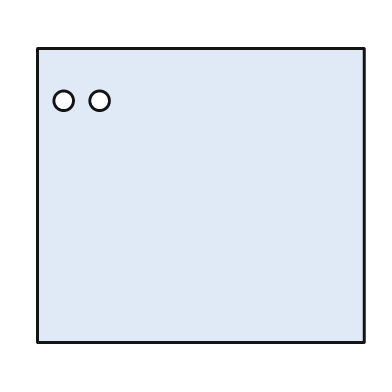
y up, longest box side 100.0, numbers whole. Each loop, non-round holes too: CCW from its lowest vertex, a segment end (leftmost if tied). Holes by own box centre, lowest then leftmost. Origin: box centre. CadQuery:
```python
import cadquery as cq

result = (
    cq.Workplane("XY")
    .moveTo(-50.0, -45.0)
    .lineTo(50.0, -45.0)
    .lineTo(50.0, 45.0)
    .lineTo(-50.0, 45.0)
    .close()
    .moveTo(-42.0, 29.0)
    .circle(3.0)
    .moveTo(-31.0, 29.0)
    .circle(3.0)
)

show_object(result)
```